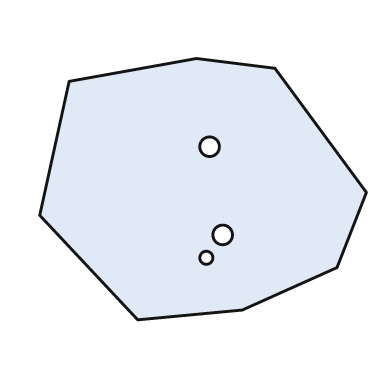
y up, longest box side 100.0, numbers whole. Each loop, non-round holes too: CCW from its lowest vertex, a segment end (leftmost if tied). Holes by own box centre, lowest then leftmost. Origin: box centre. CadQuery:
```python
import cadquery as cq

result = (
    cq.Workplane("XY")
    .moveTo(-20.0, -40.0)
    .lineTo(12.0, -37.0)
    .lineTo(41.0, -24.0)
    .lineTo(50.0, -1.0)
    .lineTo(22.0, 37.0)
    .lineTo(-2.0, 40.0)
    .lineTo(-41.0, 33.0)
    .lineTo(-50.0, -8.0)
    .close()
    .moveTo(1.0, -21.0)
    .circle(2.0)
    .moveTo(6.0, -14.0)
    .circle(3.0)
    .moveTo(2.0, 13.0)
    .circle(3.0)
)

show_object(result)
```